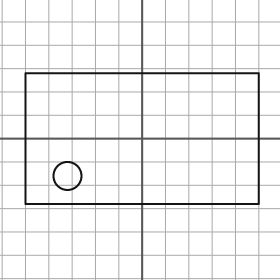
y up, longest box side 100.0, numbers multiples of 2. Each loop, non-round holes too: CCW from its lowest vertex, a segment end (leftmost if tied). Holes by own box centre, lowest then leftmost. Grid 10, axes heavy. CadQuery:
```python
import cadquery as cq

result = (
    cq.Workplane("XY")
    .moveTo(-50.0, -28.0)
    .lineTo(50.0, -28.0)
    .lineTo(50.0, 28.0)
    .lineTo(-50.0, 28.0)
    .close()
    .moveTo(-32.0, -16.0)
    .circle(6.0)
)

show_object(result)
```